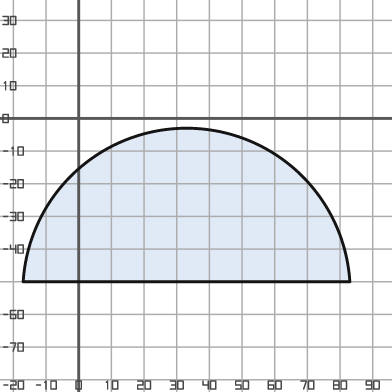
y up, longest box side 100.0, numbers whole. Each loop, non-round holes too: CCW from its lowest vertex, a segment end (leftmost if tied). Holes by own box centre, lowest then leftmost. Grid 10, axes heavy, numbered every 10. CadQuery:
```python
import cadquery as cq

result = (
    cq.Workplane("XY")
    .moveTo(-17.0, -50.0)
    .lineTo(83.0, -50.0)
    .threePointArc((33.0, -3.0), (-17.0, -50.0))
    .close()
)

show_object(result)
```